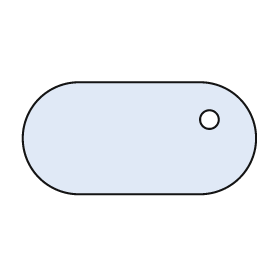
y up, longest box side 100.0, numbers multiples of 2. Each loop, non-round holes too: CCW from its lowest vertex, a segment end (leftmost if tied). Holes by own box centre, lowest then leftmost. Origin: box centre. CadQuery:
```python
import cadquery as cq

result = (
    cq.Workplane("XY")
    .moveTo(-26.0, -24.0)
    .lineTo(26.0, -24.0)
    .threePointArc((50.0, 0.0), (26.0, 24.0))
    .lineTo(-26.0, 24.0)
    .threePointArc((-50.0, 0.0), (-26.0, -24.0))
    .close()
    .moveTo(30.0, 8.0)
    .circle(4.0)
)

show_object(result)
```